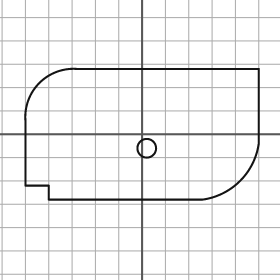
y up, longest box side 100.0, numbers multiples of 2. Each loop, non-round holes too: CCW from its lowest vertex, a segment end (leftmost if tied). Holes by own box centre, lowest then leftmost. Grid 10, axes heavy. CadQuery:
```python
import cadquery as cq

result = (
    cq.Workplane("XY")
    .moveTo(-40.0, -28.0)
    .lineTo(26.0, -28.0)
    .threePointArc((42.0, -20.0), (50.0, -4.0))
    .lineTo(50.0, 28.0)
    .lineTo(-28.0, 28.0)
    .threePointArc((-44.0, 22.0), (-50.0, 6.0))
    .lineTo(-50.0, -22.0)
    .lineTo(-40.0, -22.0)
    .close()
    .moveTo(2.0, -6.0)
    .circle(4.0)
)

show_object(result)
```